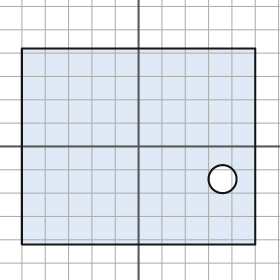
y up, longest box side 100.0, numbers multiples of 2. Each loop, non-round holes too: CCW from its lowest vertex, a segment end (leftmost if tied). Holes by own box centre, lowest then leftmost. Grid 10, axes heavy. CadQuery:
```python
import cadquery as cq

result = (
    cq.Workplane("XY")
    .moveTo(-50.0, -42.0)
    .lineTo(50.0, -42.0)
    .lineTo(50.0, 42.0)
    .lineTo(-50.0, 42.0)
    .close()
    .moveTo(36.0, -14.0)
    .circle(6.0)
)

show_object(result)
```